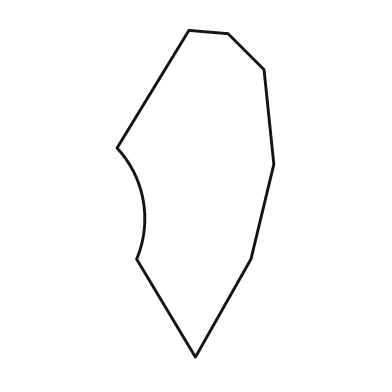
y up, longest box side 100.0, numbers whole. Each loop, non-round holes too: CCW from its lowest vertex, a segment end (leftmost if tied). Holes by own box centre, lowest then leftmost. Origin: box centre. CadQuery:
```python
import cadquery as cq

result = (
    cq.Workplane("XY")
    .moveTo(0.0, -50.0)
    .lineTo(17.0, -20.0)
    .lineTo(24.0, 9.0)
    .lineTo(21.0, 38.0)
    .lineTo(10.0, 49.0)
    .lineTo(-2.0, 50.0)
    .lineTo(-24.0, 14.0)
    .threePointArc((-16.0, -2.0), (-18.0, -20.0))
    .close()
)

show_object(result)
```